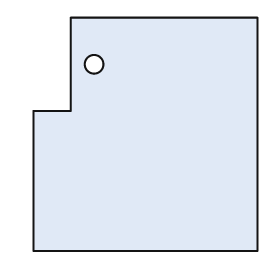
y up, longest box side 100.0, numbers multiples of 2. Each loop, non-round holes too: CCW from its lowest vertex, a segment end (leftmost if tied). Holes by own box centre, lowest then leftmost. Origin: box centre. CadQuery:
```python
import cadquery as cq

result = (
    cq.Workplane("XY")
    .moveTo(-48.0, -50.0)
    .lineTo(48.0, -50.0)
    .lineTo(48.0, 50.0)
    .lineTo(-32.0, 50.0)
    .lineTo(-32.0, 10.0)
    .lineTo(-48.0, 10.0)
    .close()
    .moveTo(-22.0, 30.0)
    .circle(4.0)
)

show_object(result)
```